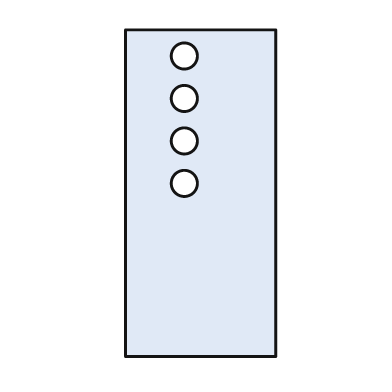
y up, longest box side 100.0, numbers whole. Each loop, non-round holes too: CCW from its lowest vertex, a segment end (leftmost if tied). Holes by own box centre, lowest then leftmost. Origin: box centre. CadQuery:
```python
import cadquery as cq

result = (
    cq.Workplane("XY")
    .moveTo(-23.0, -50.0)
    .lineTo(23.0, -50.0)
    .lineTo(23.0, 50.0)
    .lineTo(-23.0, 50.0)
    .close()
    .moveTo(-5.0, 3.0)
    .circle(4.0)
    .moveTo(-5.0, 16.0)
    .circle(4.0)
    .moveTo(-5.0, 29.0)
    .circle(4.0)
    .moveTo(-5.0, 42.0)
    .circle(4.0)
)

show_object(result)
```